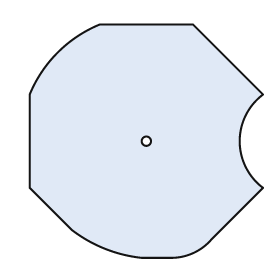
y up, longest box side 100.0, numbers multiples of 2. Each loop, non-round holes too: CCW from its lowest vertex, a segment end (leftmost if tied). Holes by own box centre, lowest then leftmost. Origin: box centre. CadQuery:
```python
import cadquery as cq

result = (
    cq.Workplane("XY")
    .moveTo(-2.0, -50.0)
    .lineTo(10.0, -50.0)
    .threePointArc((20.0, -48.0), (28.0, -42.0))
    .lineTo(50.0, -20.0)
    .threePointArc((40.0, 0.0), (50.0, 20.0))
    .lineTo(20.0, 50.0)
    .lineTo(-20.0, 50.0)
    .threePointArc((-38.0, 38.0), (-50.0, 20.0))
    .lineTo(-50.0, -20.0)
    .lineTo(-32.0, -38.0)
    .threePointArc((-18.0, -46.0), (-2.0, -50.0))
    .close()
    .moveTo(0.0, 0.0)
    .circle(2.0)
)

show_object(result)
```